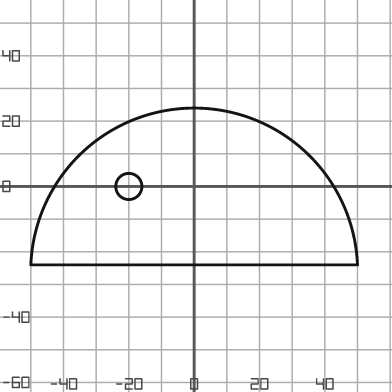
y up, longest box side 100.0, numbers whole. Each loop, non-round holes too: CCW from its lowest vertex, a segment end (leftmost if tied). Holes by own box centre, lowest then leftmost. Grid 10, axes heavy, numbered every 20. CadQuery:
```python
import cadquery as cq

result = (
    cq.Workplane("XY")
    .moveTo(-50.0, -24.0)
    .lineTo(50.0, -24.0)
    .threePointArc((0.0, 24.0), (-50.0, -24.0))
    .close()
    .moveTo(-20.0, 0.0)
    .circle(4.0)
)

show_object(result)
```